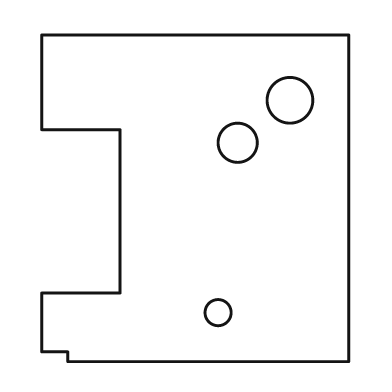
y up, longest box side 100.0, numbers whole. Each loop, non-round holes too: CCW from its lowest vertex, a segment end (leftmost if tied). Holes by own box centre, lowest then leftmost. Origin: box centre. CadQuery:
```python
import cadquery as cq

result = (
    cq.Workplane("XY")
    .moveTo(-39.0, -50.0)
    .lineTo(47.0, -50.0)
    .lineTo(47.0, 50.0)
    .lineTo(-47.0, 50.0)
    .lineTo(-47.0, 21.0)
    .lineTo(-23.0, 21.0)
    .lineTo(-23.0, -29.0)
    .lineTo(-47.0, -29.0)
    .lineTo(-47.0, -47.0)
    .lineTo(-39.0, -47.0)
    .close()
    .moveTo(7.0, -35.0)
    .circle(4.0)
    .moveTo(13.0, 17.0)
    .circle(6.0)
    .moveTo(29.0, 30.0)
    .circle(7.0)
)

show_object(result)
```